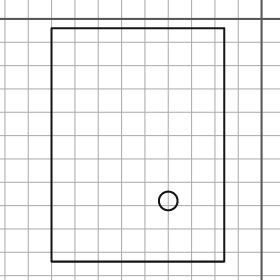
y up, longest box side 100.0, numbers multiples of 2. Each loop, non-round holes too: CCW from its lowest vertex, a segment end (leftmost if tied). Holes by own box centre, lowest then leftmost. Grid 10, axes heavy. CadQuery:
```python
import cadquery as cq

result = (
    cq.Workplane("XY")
    .moveTo(-90.0, -104.0)
    .lineTo(-16.0, -104.0)
    .lineTo(-16.0, -4.0)
    .lineTo(-90.0, -4.0)
    .close()
    .moveTo(-40.0, -78.0)
    .circle(4.0)
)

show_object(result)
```